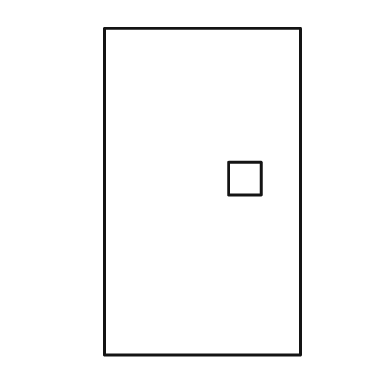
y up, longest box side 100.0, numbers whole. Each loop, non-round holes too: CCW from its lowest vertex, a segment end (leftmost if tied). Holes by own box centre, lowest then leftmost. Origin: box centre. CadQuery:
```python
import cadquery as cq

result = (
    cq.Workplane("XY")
    .moveTo(-30.0, -50.0)
    .lineTo(30.0, -50.0)
    .lineTo(30.0, 50.0)
    .lineTo(-30.0, 50.0)
    .close()
    .moveTo(8.0, -1.0)
    .lineTo(18.0, -1.0)
    .lineTo(18.0, 9.0)
    .lineTo(8.0, 9.0)
    .close()
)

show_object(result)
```